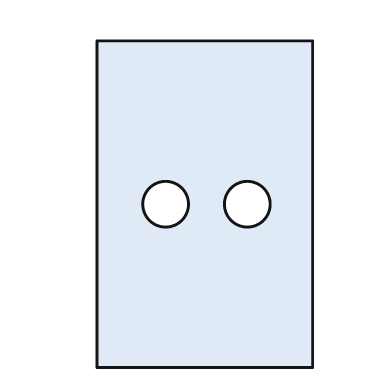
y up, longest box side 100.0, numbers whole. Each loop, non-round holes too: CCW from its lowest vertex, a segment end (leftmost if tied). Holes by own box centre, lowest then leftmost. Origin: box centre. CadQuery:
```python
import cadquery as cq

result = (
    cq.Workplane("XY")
    .moveTo(-33.0, -50.0)
    .lineTo(33.0, -50.0)
    .lineTo(33.0, 50.0)
    .lineTo(-33.0, 50.0)
    .close()
    .moveTo(-12.0, 0.0)
    .circle(7.0)
    .moveTo(13.0, 0.0)
    .circle(7.0)
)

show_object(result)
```